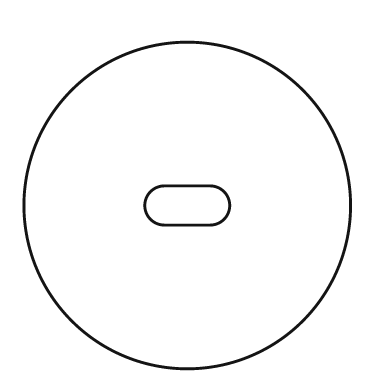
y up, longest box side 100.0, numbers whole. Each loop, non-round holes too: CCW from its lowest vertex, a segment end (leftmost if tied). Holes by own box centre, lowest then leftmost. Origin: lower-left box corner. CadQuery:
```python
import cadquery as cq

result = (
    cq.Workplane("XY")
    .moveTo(50.0, 50.0)
    .circle(50.0)
    .moveTo(43.0, 44.0)
    .lineTo(57.0, 44.0)
    .threePointArc((63.0, 50.0), (57.0, 56.0))
    .lineTo(43.0, 56.0)
    .threePointArc((37.0, 50.0), (43.0, 44.0))
    .close()
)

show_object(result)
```